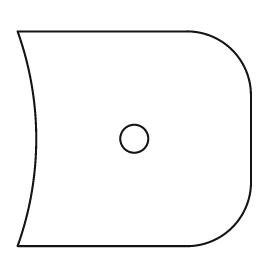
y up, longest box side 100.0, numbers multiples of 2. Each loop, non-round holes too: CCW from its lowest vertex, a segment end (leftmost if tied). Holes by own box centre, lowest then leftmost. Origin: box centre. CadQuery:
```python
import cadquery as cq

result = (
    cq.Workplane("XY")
    .moveTo(-50.0, -46.0)
    .lineTo(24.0, -46.0)
    .threePointArc((42.0, -38.0), (50.0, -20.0))
    .lineTo(50.0, 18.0)
    .threePointArc((42.0, 38.0), (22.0, 46.0))
    .lineTo(-50.0, 46.0)
    .threePointArc((-42.0, 0.0), (-50.0, -46.0))
    .close()
    .moveTo(0.0, 0.0)
    .circle(6.0)
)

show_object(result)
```